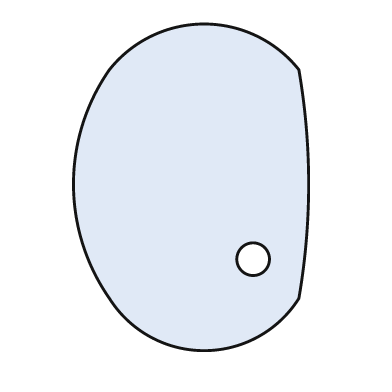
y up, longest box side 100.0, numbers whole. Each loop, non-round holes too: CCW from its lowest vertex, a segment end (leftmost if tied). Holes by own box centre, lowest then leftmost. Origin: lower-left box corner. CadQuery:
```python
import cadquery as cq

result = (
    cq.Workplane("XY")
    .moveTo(11.0, 16.0)
    .threePointArc((40.0, 0.0), (69.0, 16.0))
    .threePointArc((72.0, 51.0), (69.0, 86.0))
    .threePointArc((40.0, 100.0), (11.0, 86.0))
    .threePointArc((0.0, 51.0), (11.0, 16.0))
    .close()
    .moveTo(55.0, 28.0)
    .circle(5.0)
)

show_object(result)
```